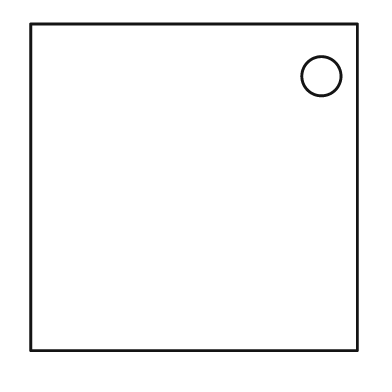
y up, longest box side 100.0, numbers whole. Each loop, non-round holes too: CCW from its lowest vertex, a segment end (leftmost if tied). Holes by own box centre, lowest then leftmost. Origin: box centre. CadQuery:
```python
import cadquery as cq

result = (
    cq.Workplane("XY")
    .moveTo(-50.0, -50.0)
    .lineTo(50.0, -50.0)
    .lineTo(50.0, 50.0)
    .lineTo(-50.0, 50.0)
    .close()
    .moveTo(39.0, 34.0)
    .circle(6.0)
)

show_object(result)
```